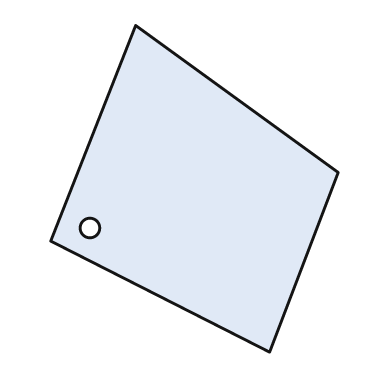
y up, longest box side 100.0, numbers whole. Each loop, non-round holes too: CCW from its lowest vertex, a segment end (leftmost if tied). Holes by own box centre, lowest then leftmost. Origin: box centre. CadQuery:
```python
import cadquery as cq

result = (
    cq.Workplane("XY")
    .moveTo(23.0, -50.0)
    .lineTo(44.0, 5.0)
    .lineTo(-18.0, 50.0)
    .lineTo(-44.0, -16.0)
    .close()
    .moveTo(-32.0, -12.0)
    .circle(3.0)
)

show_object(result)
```